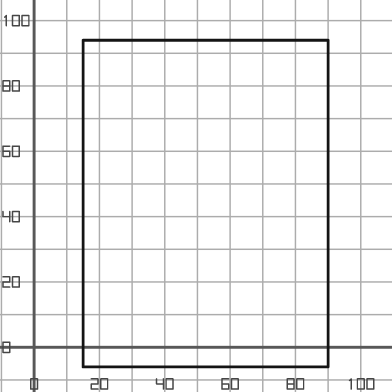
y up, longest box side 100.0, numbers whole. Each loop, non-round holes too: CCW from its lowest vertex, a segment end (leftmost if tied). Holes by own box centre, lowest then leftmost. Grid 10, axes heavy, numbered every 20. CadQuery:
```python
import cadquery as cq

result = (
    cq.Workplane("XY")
    .moveTo(15.0, -6.0)
    .lineTo(90.0, -6.0)
    .lineTo(90.0, 94.0)
    .lineTo(15.0, 94.0)
    .close()
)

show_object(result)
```